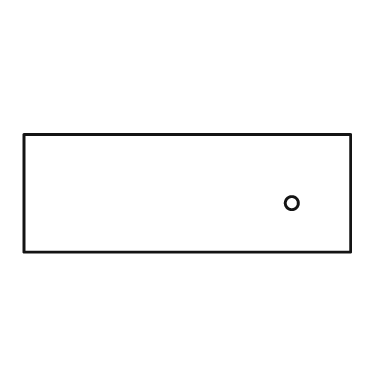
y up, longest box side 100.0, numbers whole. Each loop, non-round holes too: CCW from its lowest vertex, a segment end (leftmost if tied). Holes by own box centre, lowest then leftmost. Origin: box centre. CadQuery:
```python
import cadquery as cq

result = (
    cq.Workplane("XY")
    .moveTo(-50.0, -18.0)
    .lineTo(50.0, -18.0)
    .lineTo(50.0, 18.0)
    .lineTo(-50.0, 18.0)
    .close()
    .moveTo(32.0, -3.0)
    .circle(2.0)
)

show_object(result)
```